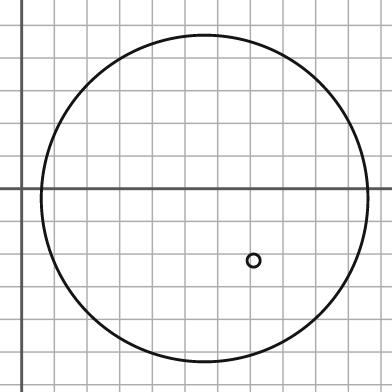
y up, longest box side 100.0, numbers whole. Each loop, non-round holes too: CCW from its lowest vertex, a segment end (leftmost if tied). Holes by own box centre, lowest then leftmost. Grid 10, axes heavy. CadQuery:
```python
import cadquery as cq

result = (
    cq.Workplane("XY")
    .moveTo(56.0, -3.0)
    .circle(50.0)
    .moveTo(71.0, -22.0)
    .circle(2.0)
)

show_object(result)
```